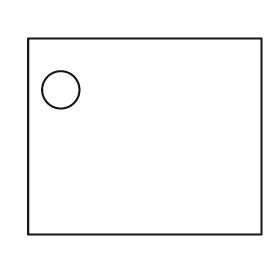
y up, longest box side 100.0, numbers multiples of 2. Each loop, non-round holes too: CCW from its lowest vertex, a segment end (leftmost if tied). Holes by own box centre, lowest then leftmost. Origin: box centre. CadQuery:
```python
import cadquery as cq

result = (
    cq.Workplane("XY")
    .moveTo(-50.0, -42.0)
    .lineTo(50.0, -42.0)
    .lineTo(50.0, 42.0)
    .lineTo(-50.0, 42.0)
    .close()
    .moveTo(-36.0, 20.0)
    .circle(8.0)
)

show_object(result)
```